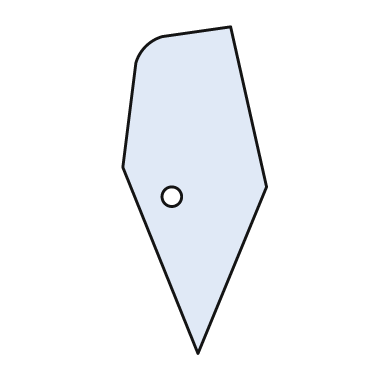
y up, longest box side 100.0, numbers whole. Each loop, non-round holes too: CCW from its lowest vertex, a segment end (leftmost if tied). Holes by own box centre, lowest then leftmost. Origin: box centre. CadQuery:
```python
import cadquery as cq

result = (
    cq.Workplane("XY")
    .moveTo(1.0, -50.0)
    .lineTo(22.0, 1.0)
    .lineTo(11.0, 50.0)
    .lineTo(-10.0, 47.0)
    .threePointArc((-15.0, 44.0), (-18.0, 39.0))
    .lineTo(-22.0, 7.0)
    .close()
    .moveTo(-7.0, -2.0)
    .circle(3.0)
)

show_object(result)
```